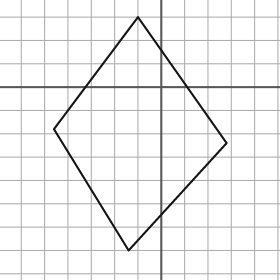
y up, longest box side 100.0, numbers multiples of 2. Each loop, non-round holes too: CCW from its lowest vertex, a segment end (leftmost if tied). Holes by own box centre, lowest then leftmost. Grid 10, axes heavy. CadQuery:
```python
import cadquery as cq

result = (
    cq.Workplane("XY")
    .moveTo(-14.0, -70.0)
    .lineTo(28.0, -24.0)
    .lineTo(-10.0, 30.0)
    .lineTo(-46.0, -18.0)
    .close()
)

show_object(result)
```